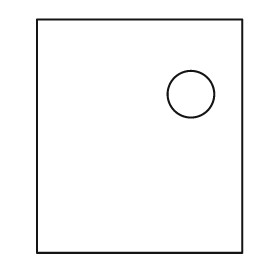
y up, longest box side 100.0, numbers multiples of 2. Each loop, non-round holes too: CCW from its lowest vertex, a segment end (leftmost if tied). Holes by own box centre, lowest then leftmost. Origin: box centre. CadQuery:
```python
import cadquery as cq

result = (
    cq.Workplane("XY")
    .moveTo(-44.0, -50.0)
    .lineTo(44.0, -50.0)
    .lineTo(44.0, 50.0)
    .lineTo(-44.0, 50.0)
    .close()
    .moveTo(22.0, 18.0)
    .circle(10.0)
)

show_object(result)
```